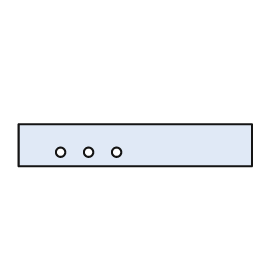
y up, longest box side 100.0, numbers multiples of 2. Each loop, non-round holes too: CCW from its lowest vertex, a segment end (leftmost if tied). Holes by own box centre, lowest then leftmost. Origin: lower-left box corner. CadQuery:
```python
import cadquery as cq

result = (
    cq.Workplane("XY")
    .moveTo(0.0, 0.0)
    .lineTo(100.0, 0.0)
    .lineTo(100.0, 18.0)
    .lineTo(0.0, 18.0)
    .close()
    .moveTo(18.0, 6.0)
    .circle(2.0)
    .moveTo(30.0, 6.0)
    .circle(2.0)
    .moveTo(42.0, 6.0)
    .circle(2.0)
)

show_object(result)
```